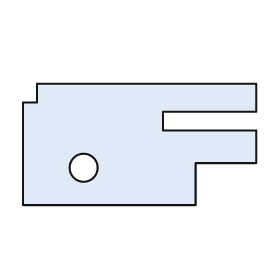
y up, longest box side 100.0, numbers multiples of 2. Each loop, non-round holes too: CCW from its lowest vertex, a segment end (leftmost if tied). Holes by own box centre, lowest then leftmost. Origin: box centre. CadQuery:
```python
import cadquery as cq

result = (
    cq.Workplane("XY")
    .moveTo(-50.0, -26.0)
    .lineTo(24.0, -26.0)
    .lineTo(24.0, -8.0)
    .lineTo(50.0, -8.0)
    .lineTo(50.0, 6.0)
    .lineTo(10.0, 6.0)
    .lineTo(10.0, 14.0)
    .lineTo(50.0, 14.0)
    .lineTo(50.0, 26.0)
    .lineTo(-44.0, 26.0)
    .lineTo(-44.0, 18.0)
    .lineTo(-50.0, 18.0)
    .close()
    .moveTo(-24.0, -10.0)
    .circle(6.0)
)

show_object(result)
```